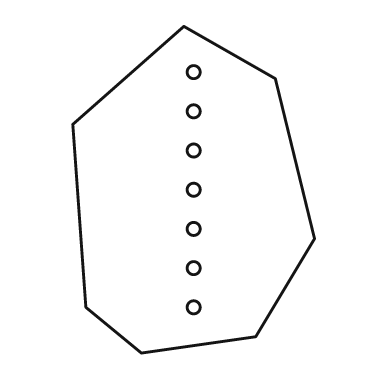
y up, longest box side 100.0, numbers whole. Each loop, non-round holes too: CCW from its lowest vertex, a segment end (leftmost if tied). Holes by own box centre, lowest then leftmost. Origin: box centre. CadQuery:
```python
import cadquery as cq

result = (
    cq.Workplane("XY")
    .moveTo(-16.0, -50.0)
    .lineTo(19.0, -45.0)
    .lineTo(37.0, -15.0)
    .lineTo(25.0, 34.0)
    .lineTo(-3.0, 50.0)
    .lineTo(-37.0, 20.0)
    .lineTo(-33.0, -36.0)
    .close()
    .moveTo(0.0, -36.0)
    .circle(2.0)
    .moveTo(0.0, -24.0)
    .circle(2.0)
    .moveTo(0.0, -12.0)
    .circle(2.0)
    .moveTo(0.0, 0.0)
    .circle(2.0)
    .moveTo(0.0, 12.0)
    .circle(2.0)
    .moveTo(0.0, 24.0)
    .circle(2.0)
    .moveTo(0.0, 36.0)
    .circle(2.0)
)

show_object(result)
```